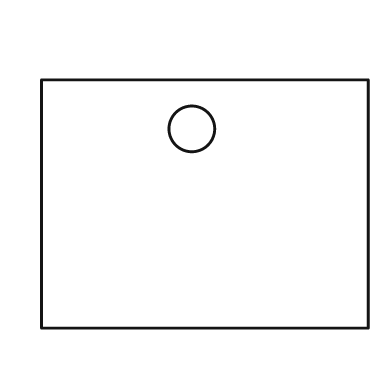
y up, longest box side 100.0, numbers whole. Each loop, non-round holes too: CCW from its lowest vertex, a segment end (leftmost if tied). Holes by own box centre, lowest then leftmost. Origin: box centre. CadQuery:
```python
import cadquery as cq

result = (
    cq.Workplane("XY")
    .moveTo(-50.0, -38.0)
    .lineTo(50.0, -38.0)
    .lineTo(50.0, 38.0)
    .lineTo(-50.0, 38.0)
    .close()
    .moveTo(-4.0, 23.0)
    .circle(7.0)
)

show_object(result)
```